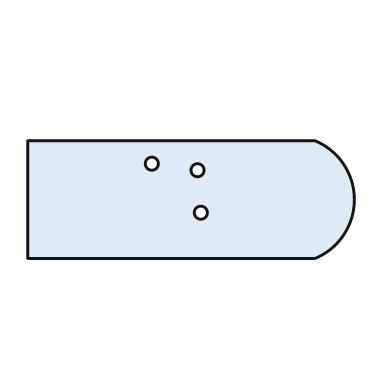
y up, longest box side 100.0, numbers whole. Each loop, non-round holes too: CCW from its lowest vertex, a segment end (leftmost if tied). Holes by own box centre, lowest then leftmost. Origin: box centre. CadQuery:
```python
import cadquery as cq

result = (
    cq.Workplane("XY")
    .moveTo(-50.0, -18.0)
    .lineTo(38.0, -18.0)
    .threePointArc((50.0, 0.0), (38.0, 18.0))
    .lineTo(-50.0, 18.0)
    .close()
    .moveTo(3.0, -4.0)
    .circle(2.0)
    .moveTo(2.0, 9.0)
    .circle(2.0)
    .moveTo(-12.0, 11.0)
    .circle(2.0)
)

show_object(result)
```